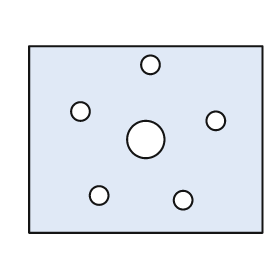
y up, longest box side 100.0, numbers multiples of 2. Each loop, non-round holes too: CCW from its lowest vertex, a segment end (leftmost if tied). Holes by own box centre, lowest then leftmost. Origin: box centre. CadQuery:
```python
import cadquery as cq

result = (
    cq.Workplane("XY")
    .moveTo(-50.0, -40.0)
    .lineTo(50.0, -40.0)
    .lineTo(50.0, 40.0)
    .lineTo(-50.0, 40.0)
    .close()
    .moveTo(16.0, -26.0)
    .circle(4.0)
    .moveTo(-20.0, -24.0)
    .circle(4.0)
    .moveTo(0.0, 0.0)
    .circle(8.0)
    .moveTo(30.0, 8.0)
    .circle(4.0)
    .moveTo(-28.0, 12.0)
    .circle(4.0)
    .moveTo(2.0, 32.0)
    .circle(4.0)
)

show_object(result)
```